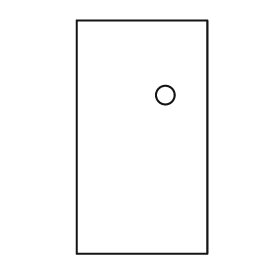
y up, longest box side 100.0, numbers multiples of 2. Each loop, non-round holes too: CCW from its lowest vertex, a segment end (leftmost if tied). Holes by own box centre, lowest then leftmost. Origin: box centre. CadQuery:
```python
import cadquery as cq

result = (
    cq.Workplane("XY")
    .moveTo(-28.0, -50.0)
    .lineTo(28.0, -50.0)
    .lineTo(28.0, 50.0)
    .lineTo(-28.0, 50.0)
    .close()
    .moveTo(10.0, 18.0)
    .circle(4.0)
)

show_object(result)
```